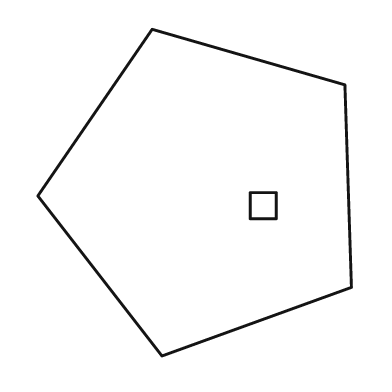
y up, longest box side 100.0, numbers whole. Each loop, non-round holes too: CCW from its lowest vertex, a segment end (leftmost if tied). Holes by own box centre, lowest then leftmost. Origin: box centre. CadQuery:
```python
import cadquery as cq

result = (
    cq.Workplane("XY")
    .moveTo(-10.0, -50.0)
    .lineTo(48.0, -29.0)
    .lineTo(46.0, 33.0)
    .lineTo(-13.0, 50.0)
    .lineTo(-48.0, -1.0)
    .close()
    .moveTo(17.0, -8.0)
    .lineTo(25.0, -8.0)
    .lineTo(25.0, 0.0)
    .lineTo(17.0, 0.0)
    .close()
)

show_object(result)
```